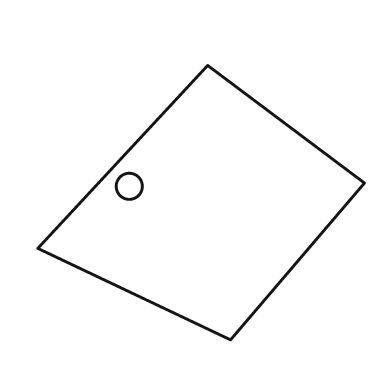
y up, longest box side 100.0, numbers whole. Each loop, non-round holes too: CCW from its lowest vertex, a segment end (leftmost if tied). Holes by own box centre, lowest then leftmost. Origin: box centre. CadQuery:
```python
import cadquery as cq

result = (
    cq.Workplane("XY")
    .moveTo(9.0, -42.0)
    .lineTo(50.0, 6.0)
    .lineTo(2.0, 42.0)
    .lineTo(-50.0, -14.0)
    .close()
    .moveTo(-22.0, 5.0)
    .circle(4.0)
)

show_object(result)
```